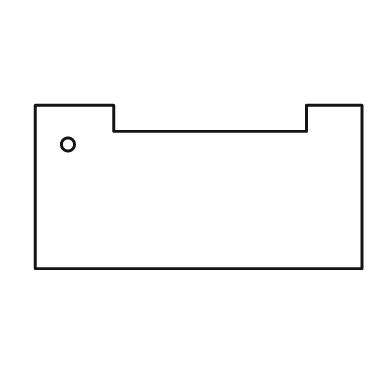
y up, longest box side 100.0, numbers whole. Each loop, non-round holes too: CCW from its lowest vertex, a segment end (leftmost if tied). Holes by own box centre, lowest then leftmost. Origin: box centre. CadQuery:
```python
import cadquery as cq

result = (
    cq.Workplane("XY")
    .moveTo(-50.0, -25.0)
    .lineTo(50.0, -25.0)
    .lineTo(50.0, 25.0)
    .lineTo(33.0, 25.0)
    .lineTo(33.0, 17.0)
    .lineTo(-26.0, 17.0)
    .lineTo(-26.0, 25.0)
    .lineTo(-50.0, 25.0)
    .close()
    .moveTo(-40.0, 13.0)
    .circle(2.0)
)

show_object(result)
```